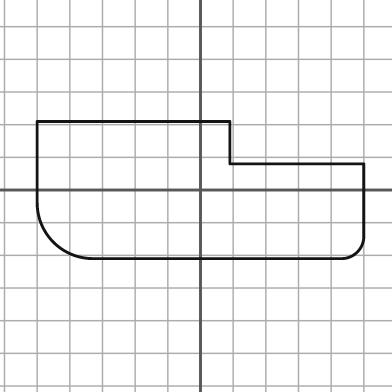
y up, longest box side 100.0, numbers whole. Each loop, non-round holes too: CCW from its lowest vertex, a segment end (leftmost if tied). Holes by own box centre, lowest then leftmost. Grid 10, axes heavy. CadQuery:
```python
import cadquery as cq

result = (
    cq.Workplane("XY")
    .moveTo(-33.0, -21.0)
    .lineTo(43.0, -21.0)
    .threePointArc((48.0, -19.0), (50.0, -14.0))
    .lineTo(50.0, 8.0)
    .lineTo(9.0, 8.0)
    .lineTo(9.0, 21.0)
    .lineTo(-50.0, 21.0)
    .lineTo(-50.0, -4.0)
    .threePointArc((-45.0, -16.0), (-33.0, -21.0))
    .close()
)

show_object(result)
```